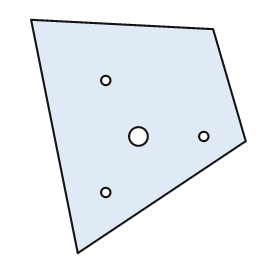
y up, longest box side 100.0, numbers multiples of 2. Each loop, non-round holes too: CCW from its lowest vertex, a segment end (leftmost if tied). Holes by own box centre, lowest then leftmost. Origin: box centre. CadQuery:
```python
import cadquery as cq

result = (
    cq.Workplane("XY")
    .moveTo(-26.0, -50.0)
    .lineTo(46.0, -2.0)
    .lineTo(32.0, 46.0)
    .lineTo(-46.0, 50.0)
    .close()
    .moveTo(-14.0, -24.0)
    .circle(2.0)
    .moveTo(0.0, 0.0)
    .circle(4.0)
    .moveTo(28.0, 0.0)
    .circle(2.0)
    .moveTo(-14.0, 24.0)
    .circle(2.0)
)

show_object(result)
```